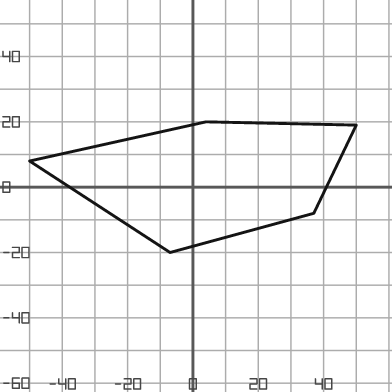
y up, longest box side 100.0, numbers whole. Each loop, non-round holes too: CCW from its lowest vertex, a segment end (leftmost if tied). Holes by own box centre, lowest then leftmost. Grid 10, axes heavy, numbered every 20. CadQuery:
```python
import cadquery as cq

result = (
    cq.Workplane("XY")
    .moveTo(-7.0, -20.0)
    .lineTo(37.0, -8.0)
    .lineTo(50.0, 19.0)
    .lineTo(4.0, 20.0)
    .lineTo(-50.0, 8.0)
    .close()
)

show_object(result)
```